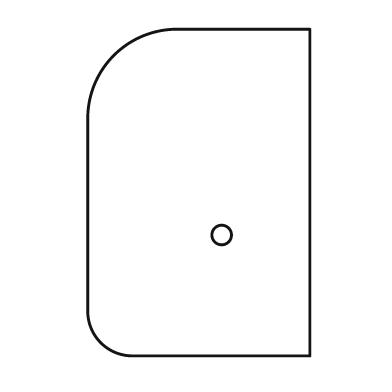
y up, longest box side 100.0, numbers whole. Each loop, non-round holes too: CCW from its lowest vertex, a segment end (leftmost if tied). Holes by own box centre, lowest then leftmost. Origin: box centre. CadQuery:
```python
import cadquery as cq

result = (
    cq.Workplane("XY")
    .moveTo(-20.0, -50.0)
    .lineTo(34.0, -50.0)
    .lineTo(34.0, 50.0)
    .lineTo(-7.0, 50.0)
    .threePointArc((-26.0, 42.0), (-34.0, 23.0))
    .lineTo(-34.0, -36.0)
    .threePointArc((-30.0, -46.0), (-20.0, -50.0))
    .close()
    .moveTo(7.0, -13.0)
    .circle(3.0)
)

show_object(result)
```